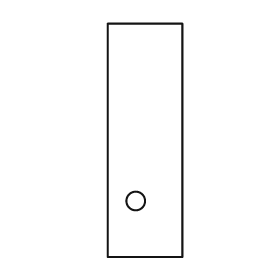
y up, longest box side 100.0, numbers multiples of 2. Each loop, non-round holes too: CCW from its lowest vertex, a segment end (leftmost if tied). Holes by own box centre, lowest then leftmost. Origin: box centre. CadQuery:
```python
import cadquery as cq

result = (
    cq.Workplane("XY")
    .moveTo(-16.0, -50.0)
    .lineTo(16.0, -50.0)
    .lineTo(16.0, 50.0)
    .lineTo(-16.0, 50.0)
    .close()
    .moveTo(-4.0, -26.0)
    .circle(4.0)
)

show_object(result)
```